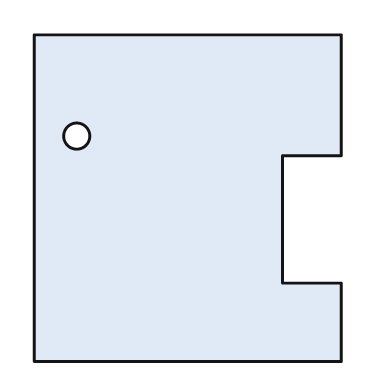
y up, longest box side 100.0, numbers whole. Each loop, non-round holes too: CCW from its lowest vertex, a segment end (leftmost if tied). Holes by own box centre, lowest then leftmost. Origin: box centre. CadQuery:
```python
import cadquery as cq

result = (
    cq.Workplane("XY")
    .moveTo(-47.0, -50.0)
    .lineTo(47.0, -50.0)
    .lineTo(47.0, -26.0)
    .lineTo(29.0, -26.0)
    .lineTo(29.0, 13.0)
    .lineTo(47.0, 13.0)
    .lineTo(47.0, 50.0)
    .lineTo(-47.0, 50.0)
    .close()
    .moveTo(-34.0, 19.0)
    .circle(4.0)
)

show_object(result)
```